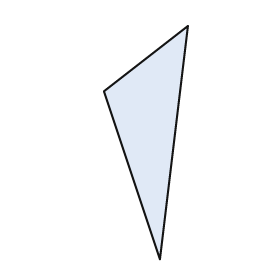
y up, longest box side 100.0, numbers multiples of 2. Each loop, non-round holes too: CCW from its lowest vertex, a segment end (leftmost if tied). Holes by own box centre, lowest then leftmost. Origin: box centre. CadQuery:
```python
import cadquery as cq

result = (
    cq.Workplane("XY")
    .moveTo(6.0, -50.0)
    .lineTo(18.0, 50.0)
    .lineTo(-18.0, 22.0)
    .close()
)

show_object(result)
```